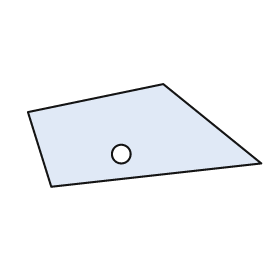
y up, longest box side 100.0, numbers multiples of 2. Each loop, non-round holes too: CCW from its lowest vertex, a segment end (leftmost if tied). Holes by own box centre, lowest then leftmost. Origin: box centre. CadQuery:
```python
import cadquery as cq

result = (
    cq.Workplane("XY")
    .moveTo(-40.0, -22.0)
    .lineTo(50.0, -12.0)
    .lineTo(8.0, 22.0)
    .lineTo(-50.0, 10.0)
    .close()
    .moveTo(-10.0, -8.0)
    .circle(4.0)
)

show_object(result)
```